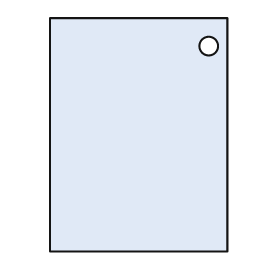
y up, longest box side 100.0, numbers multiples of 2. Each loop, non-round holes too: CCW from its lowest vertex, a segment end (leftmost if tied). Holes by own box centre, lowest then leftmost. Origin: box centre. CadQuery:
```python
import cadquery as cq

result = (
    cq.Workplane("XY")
    .moveTo(-38.0, -50.0)
    .lineTo(38.0, -50.0)
    .lineTo(38.0, 50.0)
    .lineTo(-38.0, 50.0)
    .close()
    .moveTo(30.0, 38.0)
    .circle(4.0)
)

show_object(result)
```